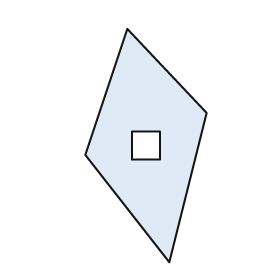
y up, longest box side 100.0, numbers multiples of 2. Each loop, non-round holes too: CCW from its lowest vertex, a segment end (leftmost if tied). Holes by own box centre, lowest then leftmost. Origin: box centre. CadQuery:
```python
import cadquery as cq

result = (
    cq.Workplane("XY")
    .moveTo(10.0, -50.0)
    .lineTo(26.0, 14.0)
    .lineTo(-8.0, 50.0)
    .lineTo(-26.0, -4.0)
    .close()
    .moveTo(-6.0, -6.0)
    .lineTo(6.0, -6.0)
    .lineTo(6.0, 6.0)
    .lineTo(-6.0, 6.0)
    .close()
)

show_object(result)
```